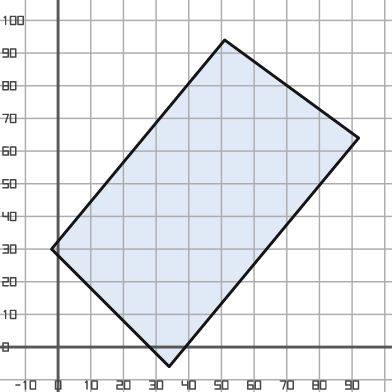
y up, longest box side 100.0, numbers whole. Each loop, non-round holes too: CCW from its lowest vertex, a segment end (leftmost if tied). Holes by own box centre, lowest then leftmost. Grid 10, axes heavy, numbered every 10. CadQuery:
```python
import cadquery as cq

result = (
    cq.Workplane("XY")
    .moveTo(34.0, -6.0)
    .lineTo(92.0, 64.0)
    .lineTo(51.0, 94.0)
    .lineTo(-2.0, 30.0)
    .close()
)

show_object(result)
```